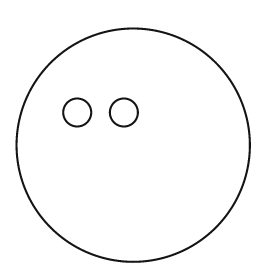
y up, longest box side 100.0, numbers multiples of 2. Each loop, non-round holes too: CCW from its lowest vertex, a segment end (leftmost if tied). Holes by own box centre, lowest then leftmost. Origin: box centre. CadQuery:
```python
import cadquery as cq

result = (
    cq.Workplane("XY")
    .moveTo(0.0, 0.0)
    .circle(50.0)
    .moveTo(-24.0, 14.0)
    .circle(6.0)
    .moveTo(-4.0, 14.0)
    .circle(6.0)
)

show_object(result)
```